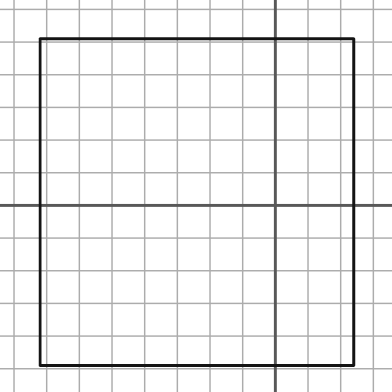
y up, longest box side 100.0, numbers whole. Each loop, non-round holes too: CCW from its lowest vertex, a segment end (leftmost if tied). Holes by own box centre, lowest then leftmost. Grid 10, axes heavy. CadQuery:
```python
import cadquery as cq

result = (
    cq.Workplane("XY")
    .moveTo(-72.0, -49.0)
    .lineTo(24.0, -49.0)
    .lineTo(24.0, 51.0)
    .lineTo(-72.0, 51.0)
    .close()
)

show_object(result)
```